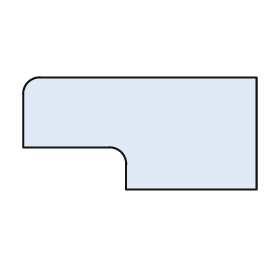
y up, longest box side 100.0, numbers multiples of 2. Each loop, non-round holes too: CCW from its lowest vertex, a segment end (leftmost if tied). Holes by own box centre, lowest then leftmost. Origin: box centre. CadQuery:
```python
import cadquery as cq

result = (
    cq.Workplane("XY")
    .moveTo(-6.0, -24.0)
    .lineTo(50.0, -24.0)
    .lineTo(50.0, 24.0)
    .lineTo(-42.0, 24.0)
    .threePointArc((-48.0, 22.0), (-50.0, 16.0))
    .lineTo(-50.0, -6.0)
    .lineTo(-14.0, -6.0)
    .threePointArc((-8.0, -8.0), (-6.0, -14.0))
    .close()
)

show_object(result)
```